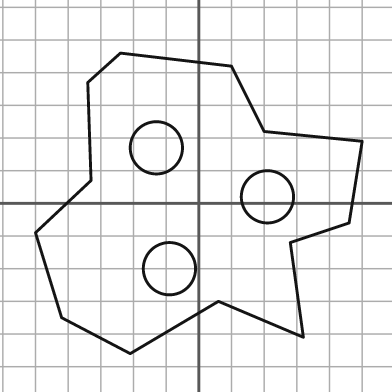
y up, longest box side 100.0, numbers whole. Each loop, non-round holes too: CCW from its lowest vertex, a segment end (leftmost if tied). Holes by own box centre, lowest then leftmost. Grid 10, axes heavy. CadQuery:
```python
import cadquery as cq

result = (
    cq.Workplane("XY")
    .moveTo(-21.0, -46.0)
    .lineTo(6.0, -30.0)
    .lineTo(32.0, -41.0)
    .lineTo(28.0, -12.0)
    .lineTo(46.0, -6.0)
    .lineTo(50.0, 19.0)
    .lineTo(20.0, 22.0)
    .lineTo(10.0, 42.0)
    .lineTo(-24.0, 46.0)
    .lineTo(-34.0, 37.0)
    .lineTo(-33.0, 7.0)
    .lineTo(-50.0, -9.0)
    .lineTo(-42.0, -35.0)
    .close()
    .moveTo(-9.0, -20.0)
    .circle(8.0)
    .moveTo(21.0, 2.0)
    .circle(8.0)
    .moveTo(-13.0, 17.0)
    .circle(8.0)
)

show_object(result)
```